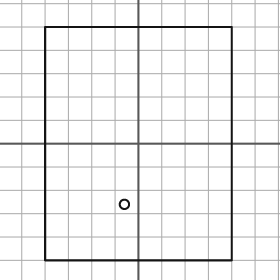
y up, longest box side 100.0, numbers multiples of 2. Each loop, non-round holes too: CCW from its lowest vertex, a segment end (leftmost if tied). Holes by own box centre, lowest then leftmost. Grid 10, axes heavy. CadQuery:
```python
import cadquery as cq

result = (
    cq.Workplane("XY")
    .moveTo(-40.0, -50.0)
    .lineTo(40.0, -50.0)
    .lineTo(40.0, 50.0)
    .lineTo(-40.0, 50.0)
    .close()
    .moveTo(-6.0, -26.0)
    .circle(2.0)
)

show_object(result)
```